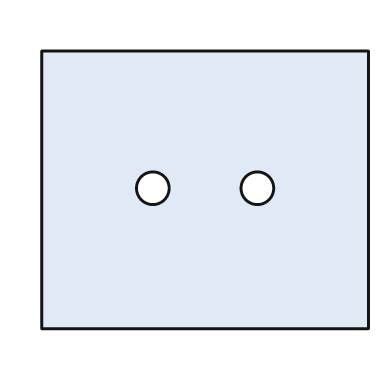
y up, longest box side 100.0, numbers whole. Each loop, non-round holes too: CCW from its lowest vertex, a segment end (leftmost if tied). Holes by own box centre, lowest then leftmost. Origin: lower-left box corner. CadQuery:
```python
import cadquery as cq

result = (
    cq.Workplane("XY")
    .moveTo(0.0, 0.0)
    .lineTo(100.0, 0.0)
    .lineTo(100.0, 85.0)
    .lineTo(0.0, 85.0)
    .close()
    .moveTo(34.0, 43.0)
    .circle(5.0)
    .moveTo(66.0, 43.0)
    .circle(5.0)
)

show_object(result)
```